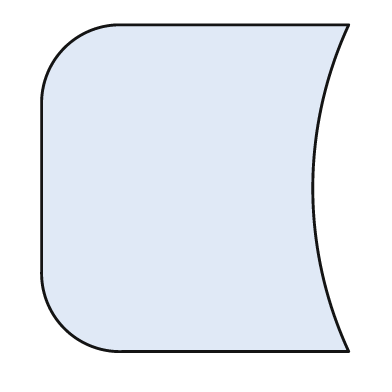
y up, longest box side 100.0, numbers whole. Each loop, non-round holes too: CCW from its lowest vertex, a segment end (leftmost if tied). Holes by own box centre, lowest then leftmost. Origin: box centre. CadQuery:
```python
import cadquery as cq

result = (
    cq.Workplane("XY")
    .moveTo(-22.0, -50.0)
    .lineTo(47.0, -50.0)
    .threePointArc((36.0, 0.0), (47.0, 50.0))
    .lineTo(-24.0, 50.0)
    .threePointArc((-40.0, 43.0), (-47.0, 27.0))
    .lineTo(-47.0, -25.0)
    .threePointArc((-40.0, -43.0), (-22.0, -50.0))
    .close()
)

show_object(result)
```